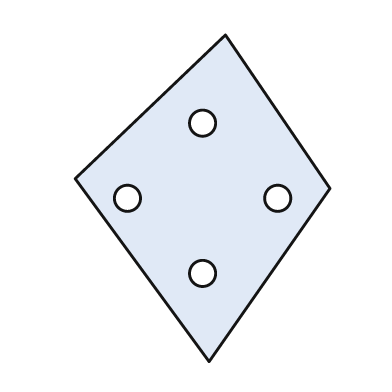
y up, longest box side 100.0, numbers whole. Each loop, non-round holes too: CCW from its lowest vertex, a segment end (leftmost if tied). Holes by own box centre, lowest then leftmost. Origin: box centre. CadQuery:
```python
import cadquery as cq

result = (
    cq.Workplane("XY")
    .moveTo(2.0, -50.0)
    .lineTo(39.0, 3.0)
    .lineTo(7.0, 50.0)
    .lineTo(-39.0, 6.0)
    .close()
    .moveTo(0.0, -23.0)
    .circle(4.0)
    .moveTo(-23.0, 0.0)
    .circle(4.0)
    .moveTo(23.0, 0.0)
    .circle(4.0)
    .moveTo(0.0, 23.0)
    .circle(4.0)
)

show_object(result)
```